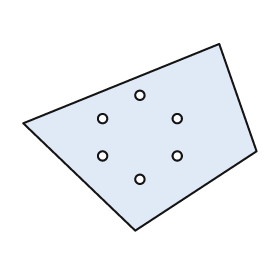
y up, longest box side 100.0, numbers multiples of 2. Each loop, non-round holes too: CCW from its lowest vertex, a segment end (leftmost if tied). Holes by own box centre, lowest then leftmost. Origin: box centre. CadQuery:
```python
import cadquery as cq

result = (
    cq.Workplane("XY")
    .moveTo(-2.0, -40.0)
    .lineTo(50.0, -6.0)
    .lineTo(34.0, 40.0)
    .lineTo(-50.0, 6.0)
    .close()
    .moveTo(0.0, -18.0)
    .circle(2.0)
    .moveTo(-16.0, -8.0)
    .circle(2.0)
    .moveTo(16.0, -8.0)
    .circle(2.0)
    .moveTo(-16.0, 8.0)
    .circle(2.0)
    .moveTo(16.0, 8.0)
    .circle(2.0)
    .moveTo(0.0, 18.0)
    .circle(2.0)
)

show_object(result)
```